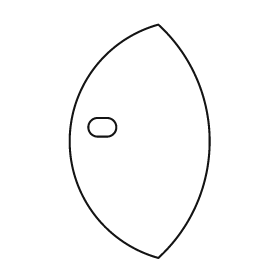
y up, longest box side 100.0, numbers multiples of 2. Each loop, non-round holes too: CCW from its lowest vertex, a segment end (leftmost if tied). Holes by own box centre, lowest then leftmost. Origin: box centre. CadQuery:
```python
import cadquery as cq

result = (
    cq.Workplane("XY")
    .moveTo(8.0, -50.0)
    .threePointArc((30.0, 0.0), (8.0, 50.0))
    .threePointArc((-30.0, 0.0), (8.0, -50.0))
    .close()
    .moveTo(-18.0, 2.0)
    .lineTo(-14.0, 2.0)
    .threePointArc((-10.0, 6.0), (-14.0, 10.0))
    .lineTo(-18.0, 10.0)
    .threePointArc((-22.0, 6.0), (-18.0, 2.0))
    .close()
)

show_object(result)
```